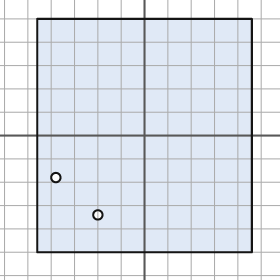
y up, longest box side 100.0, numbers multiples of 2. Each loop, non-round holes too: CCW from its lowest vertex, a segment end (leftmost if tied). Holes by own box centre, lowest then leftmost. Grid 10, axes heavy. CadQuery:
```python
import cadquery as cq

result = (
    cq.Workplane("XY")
    .moveTo(-46.0, -50.0)
    .lineTo(46.0, -50.0)
    .lineTo(46.0, 50.0)
    .lineTo(-46.0, 50.0)
    .close()
    .moveTo(-20.0, -34.0)
    .circle(2.0)
    .moveTo(-38.0, -18.0)
    .circle(2.0)
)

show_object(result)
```